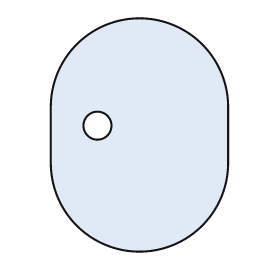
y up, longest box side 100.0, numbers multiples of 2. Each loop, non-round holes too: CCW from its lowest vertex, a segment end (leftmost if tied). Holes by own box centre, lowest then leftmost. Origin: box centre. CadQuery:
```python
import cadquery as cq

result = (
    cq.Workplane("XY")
    .moveTo(-38.0, -12.0)
    .threePointArc((0.0, -50.0), (38.0, -12.0))
    .lineTo(38.0, 12.0)
    .threePointArc((0.0, 50.0), (-38.0, 12.0))
    .close()
    .moveTo(-18.0, 4.0)
    .circle(6.0)
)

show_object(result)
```